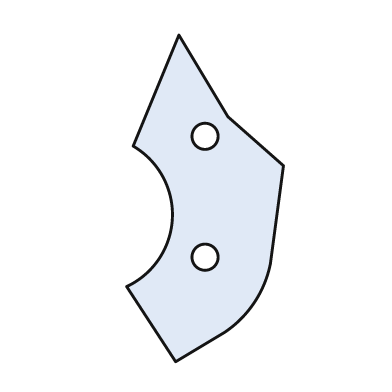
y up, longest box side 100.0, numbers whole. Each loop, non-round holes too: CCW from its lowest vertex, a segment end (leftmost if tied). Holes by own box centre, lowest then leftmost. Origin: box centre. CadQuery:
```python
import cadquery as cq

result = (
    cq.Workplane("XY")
    .moveTo(-9.0, -50.0)
    .lineTo(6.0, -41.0)
    .threePointArc((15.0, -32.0), (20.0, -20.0))
    .lineTo(24.0, 10.0)
    .lineTo(7.0, 25.0)
    .lineTo(-8.0, 50.0)
    .lineTo(-22.0, 16.0)
    .threePointArc((-10.0, -6.0), (-24.0, -27.0))
    .close()
    .moveTo(0.0, -18.0)
    .circle(4.0)
    .moveTo(0.0, 19.0)
    .circle(4.0)
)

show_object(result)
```